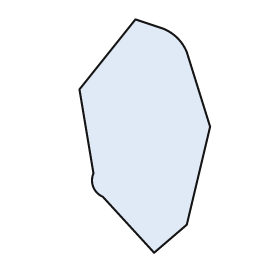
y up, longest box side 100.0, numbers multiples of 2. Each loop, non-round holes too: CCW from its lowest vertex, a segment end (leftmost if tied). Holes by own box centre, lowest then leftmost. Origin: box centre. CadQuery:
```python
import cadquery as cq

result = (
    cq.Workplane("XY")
    .moveTo(4.0, -50.0)
    .lineTo(18.0, -38.0)
    .lineTo(28.0, 4.0)
    .lineTo(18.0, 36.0)
    .threePointArc((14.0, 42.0), (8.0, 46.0))
    .lineTo(-4.0, 50.0)
    .lineTo(-28.0, 20.0)
    .lineTo(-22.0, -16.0)
    .threePointArc((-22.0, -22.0), (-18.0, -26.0))
    .close()
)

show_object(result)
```